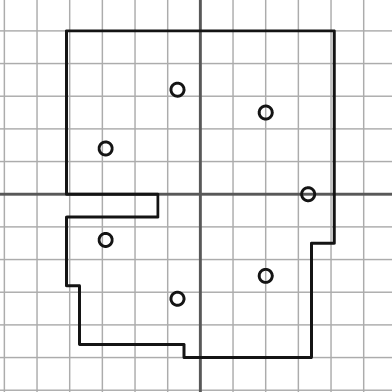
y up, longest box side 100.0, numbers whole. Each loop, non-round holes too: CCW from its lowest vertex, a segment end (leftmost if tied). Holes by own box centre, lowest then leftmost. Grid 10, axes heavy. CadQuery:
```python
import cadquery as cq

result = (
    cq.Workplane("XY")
    .moveTo(-5.0, -50.0)
    .lineTo(34.0, -50.0)
    .lineTo(34.0, -15.0)
    .lineTo(41.0, -15.0)
    .lineTo(41.0, 50.0)
    .lineTo(-41.0, 50.0)
    .lineTo(-41.0, 0.0)
    .lineTo(-13.0, 0.0)
    .lineTo(-13.0, -7.0)
    .lineTo(-41.0, -7.0)
    .lineTo(-41.0, -28.0)
    .lineTo(-37.0, -28.0)
    .lineTo(-37.0, -46.0)
    .lineTo(-5.0, -46.0)
    .close()
    .moveTo(-7.0, -32.0)
    .circle(2.0)
    .moveTo(20.0, -25.0)
    .circle(2.0)
    .moveTo(-29.0, -14.0)
    .circle(2.0)
    .moveTo(33.0, 0.0)
    .circle(2.0)
    .moveTo(-29.0, 14.0)
    .circle(2.0)
    .moveTo(20.0, 25.0)
    .circle(2.0)
    .moveTo(-7.0, 32.0)
    .circle(2.0)
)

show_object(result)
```